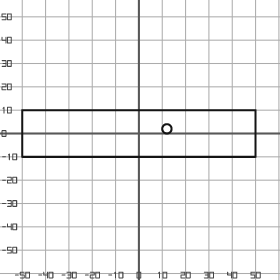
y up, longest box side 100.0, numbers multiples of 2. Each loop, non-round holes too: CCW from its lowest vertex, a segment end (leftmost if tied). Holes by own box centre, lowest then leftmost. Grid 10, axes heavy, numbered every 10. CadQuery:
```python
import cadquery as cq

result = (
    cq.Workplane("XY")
    .moveTo(-50.0, -10.0)
    .lineTo(50.0, -10.0)
    .lineTo(50.0, 10.0)
    .lineTo(-50.0, 10.0)
    .close()
    .moveTo(12.0, 2.0)
    .circle(2.0)
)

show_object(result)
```